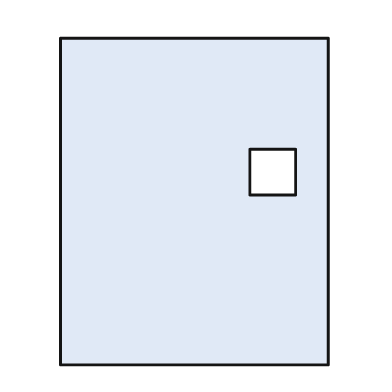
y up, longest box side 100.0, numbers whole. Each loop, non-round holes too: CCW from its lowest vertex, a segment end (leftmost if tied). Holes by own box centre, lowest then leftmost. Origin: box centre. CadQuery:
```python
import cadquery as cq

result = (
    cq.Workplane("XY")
    .moveTo(-41.0, -50.0)
    .lineTo(41.0, -50.0)
    .lineTo(41.0, 50.0)
    .lineTo(-41.0, 50.0)
    .close()
    .moveTo(17.0, 2.0)
    .lineTo(31.0, 2.0)
    .lineTo(31.0, 16.0)
    .lineTo(17.0, 16.0)
    .close()
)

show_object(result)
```